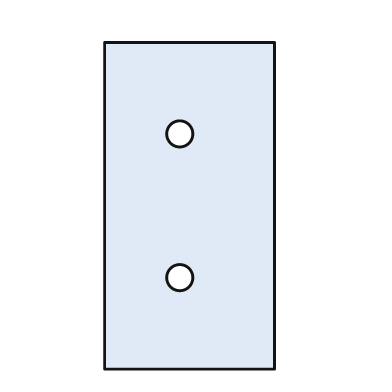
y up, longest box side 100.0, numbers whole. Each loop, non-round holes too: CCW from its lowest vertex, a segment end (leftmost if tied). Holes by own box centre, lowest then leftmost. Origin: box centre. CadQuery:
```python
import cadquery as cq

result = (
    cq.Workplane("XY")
    .moveTo(-26.0, -50.0)
    .lineTo(26.0, -50.0)
    .lineTo(26.0, 50.0)
    .lineTo(-26.0, 50.0)
    .close()
    .moveTo(-3.0, -22.0)
    .circle(4.0)
    .moveTo(-3.0, 22.0)
    .circle(4.0)
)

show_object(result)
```